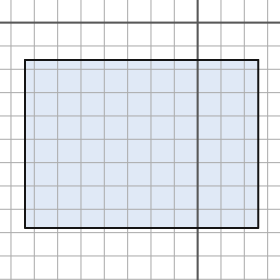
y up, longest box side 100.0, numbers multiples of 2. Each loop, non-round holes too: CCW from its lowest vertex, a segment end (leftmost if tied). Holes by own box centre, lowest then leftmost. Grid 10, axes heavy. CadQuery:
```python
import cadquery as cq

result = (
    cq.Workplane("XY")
    .moveTo(-74.0, -88.0)
    .lineTo(26.0, -88.0)
    .lineTo(26.0, -16.0)
    .lineTo(-74.0, -16.0)
    .close()
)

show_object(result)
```